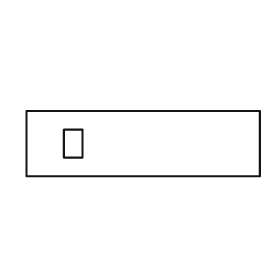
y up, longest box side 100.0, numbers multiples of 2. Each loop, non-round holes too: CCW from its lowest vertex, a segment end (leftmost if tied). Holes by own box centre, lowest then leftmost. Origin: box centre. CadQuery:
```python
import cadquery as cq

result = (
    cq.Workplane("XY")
    .moveTo(-50.0, -14.0)
    .lineTo(50.0, -14.0)
    .lineTo(50.0, 14.0)
    .lineTo(-50.0, 14.0)
    .close()
    .moveTo(-34.0, -6.0)
    .lineTo(-26.0, -6.0)
    .lineTo(-26.0, 6.0)
    .lineTo(-34.0, 6.0)
    .close()
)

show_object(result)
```